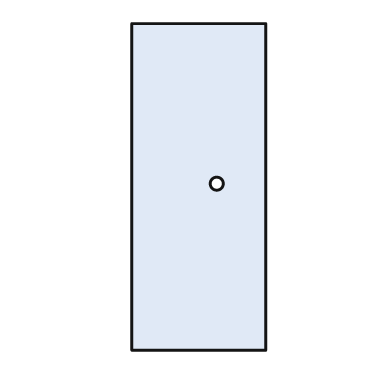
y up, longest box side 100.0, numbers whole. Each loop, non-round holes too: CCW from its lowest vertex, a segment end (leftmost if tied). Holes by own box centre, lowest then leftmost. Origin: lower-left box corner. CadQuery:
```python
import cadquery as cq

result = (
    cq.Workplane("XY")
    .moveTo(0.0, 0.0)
    .lineTo(41.0, 0.0)
    .lineTo(41.0, 100.0)
    .lineTo(0.0, 100.0)
    .close()
    .moveTo(26.0, 51.0)
    .circle(2.0)
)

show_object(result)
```